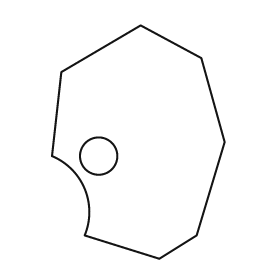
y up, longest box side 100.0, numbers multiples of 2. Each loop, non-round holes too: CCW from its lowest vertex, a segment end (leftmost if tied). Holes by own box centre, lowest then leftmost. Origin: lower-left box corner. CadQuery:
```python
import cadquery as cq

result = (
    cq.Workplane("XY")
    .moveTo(46.0, 0.0)
    .lineTo(62.0, 10.0)
    .lineTo(74.0, 50.0)
    .lineTo(64.0, 86.0)
    .lineTo(38.0, 100.0)
    .lineTo(4.0, 80.0)
    .lineTo(0.0, 44.0)
    .threePointArc((14.0, 30.0), (14.0, 10.0))
    .close()
    .moveTo(20.0, 44.0)
    .circle(8.0)
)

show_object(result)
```